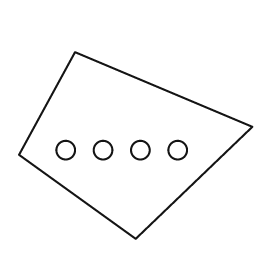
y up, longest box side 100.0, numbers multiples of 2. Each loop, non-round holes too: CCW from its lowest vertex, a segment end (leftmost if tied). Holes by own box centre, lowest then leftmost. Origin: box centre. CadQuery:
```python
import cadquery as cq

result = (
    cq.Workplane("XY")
    .moveTo(0.0, -40.0)
    .lineTo(50.0, 8.0)
    .lineTo(-26.0, 40.0)
    .lineTo(-50.0, -4.0)
    .close()
    .moveTo(-30.0, -2.0)
    .circle(4.0)
    .moveTo(-14.0, -2.0)
    .circle(4.0)
    .moveTo(2.0, -2.0)
    .circle(4.0)
    .moveTo(18.0, -2.0)
    .circle(4.0)
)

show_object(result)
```